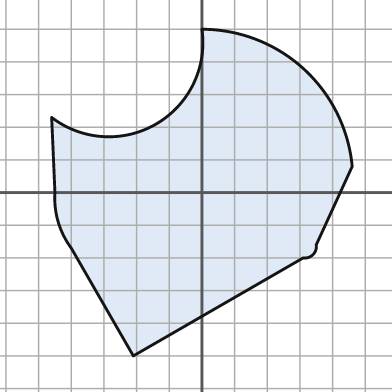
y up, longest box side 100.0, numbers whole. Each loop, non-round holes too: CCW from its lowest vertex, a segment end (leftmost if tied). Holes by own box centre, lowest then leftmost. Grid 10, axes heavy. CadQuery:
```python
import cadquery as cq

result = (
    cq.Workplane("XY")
    .moveTo(-21.0, -50.0)
    .lineTo(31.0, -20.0)
    .threePointArc((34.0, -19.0), (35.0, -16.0))
    .lineTo(46.0, 8.0)
    .threePointArc((31.0, 38.0), (0.0, 50.0))
    .threePointArc((-14.0, 21.0), (-46.0, 23.0))
    .lineTo(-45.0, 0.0)
    .threePointArc((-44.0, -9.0), (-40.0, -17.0))
    .close()
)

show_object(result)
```